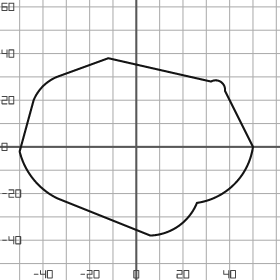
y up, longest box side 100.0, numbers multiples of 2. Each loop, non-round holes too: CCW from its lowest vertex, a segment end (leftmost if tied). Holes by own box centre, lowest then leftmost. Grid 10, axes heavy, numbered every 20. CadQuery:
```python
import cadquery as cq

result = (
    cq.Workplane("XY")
    .moveTo(6.0, -38.0)
    .threePointArc((18.0, -34.0), (26.0, -24.0))
    .threePointArc((42.0, -16.0), (50.0, 0.0))
    .lineTo(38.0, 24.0)
    .threePointArc((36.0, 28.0), (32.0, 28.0))
    .lineTo(-12.0, 38.0)
    .lineTo(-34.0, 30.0)
    .threePointArc((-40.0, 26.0), (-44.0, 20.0))
    .lineTo(-50.0, -2.0)
    .threePointArc((-44.0, -14.0), (-34.0, -22.0))
    .close()
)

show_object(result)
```